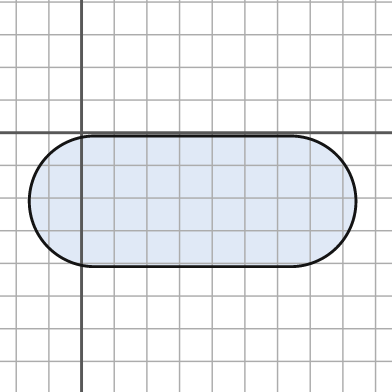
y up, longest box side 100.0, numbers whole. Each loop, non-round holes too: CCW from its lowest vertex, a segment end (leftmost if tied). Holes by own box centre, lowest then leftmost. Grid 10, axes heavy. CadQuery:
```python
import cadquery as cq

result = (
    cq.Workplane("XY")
    .moveTo(4.0, -41.0)
    .lineTo(64.0, -41.0)
    .threePointArc((84.0, -21.0), (64.0, -1.0))
    .lineTo(4.0, -1.0)
    .threePointArc((-16.0, -21.0), (4.0, -41.0))
    .close()
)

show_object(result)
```